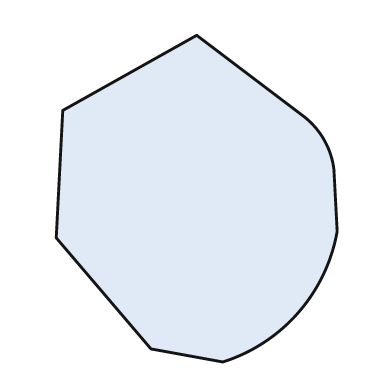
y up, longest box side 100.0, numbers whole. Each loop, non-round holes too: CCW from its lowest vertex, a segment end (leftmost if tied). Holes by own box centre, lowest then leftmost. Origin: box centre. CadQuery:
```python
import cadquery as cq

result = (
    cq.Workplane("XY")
    .moveTo(8.0, -50.0)
    .threePointArc((31.0, -35.0), (43.0, -10.0))
    .lineTo(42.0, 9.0)
    .threePointArc((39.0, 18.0), (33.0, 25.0))
    .lineTo(0.0, 50.0)
    .lineTo(-41.0, 27.0)
    .lineTo(-43.0, -12.0)
    .lineTo(-14.0, -46.0)
    .close()
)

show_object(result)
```